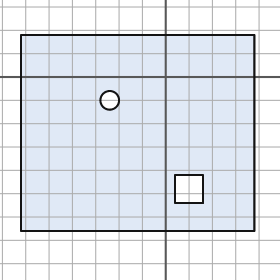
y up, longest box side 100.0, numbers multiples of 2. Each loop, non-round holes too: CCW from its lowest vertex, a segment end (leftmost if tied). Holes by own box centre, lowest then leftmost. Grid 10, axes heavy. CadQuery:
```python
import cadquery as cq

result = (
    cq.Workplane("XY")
    .moveTo(-62.0, -66.0)
    .lineTo(38.0, -66.0)
    .lineTo(38.0, 18.0)
    .lineTo(-62.0, 18.0)
    .close()
    .moveTo(4.0, -54.0)
    .lineTo(16.0, -54.0)
    .lineTo(16.0, -42.0)
    .lineTo(4.0, -42.0)
    .close()
    .moveTo(-24.0, -10.0)
    .circle(4.0)
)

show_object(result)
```